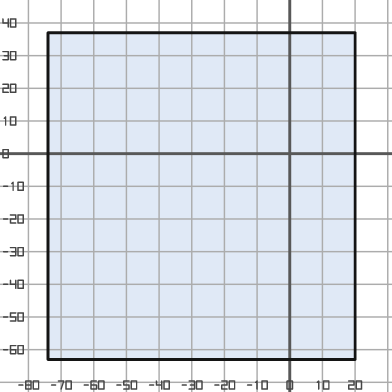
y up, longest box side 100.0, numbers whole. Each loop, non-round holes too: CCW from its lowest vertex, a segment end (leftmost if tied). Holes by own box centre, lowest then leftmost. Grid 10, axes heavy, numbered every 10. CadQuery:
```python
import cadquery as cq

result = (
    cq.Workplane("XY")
    .moveTo(-74.0, -63.0)
    .lineTo(20.0, -63.0)
    .lineTo(20.0, 37.0)
    .lineTo(-74.0, 37.0)
    .close()
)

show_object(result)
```